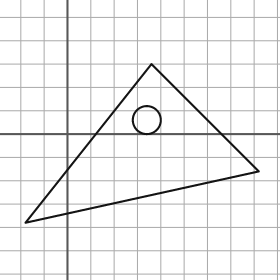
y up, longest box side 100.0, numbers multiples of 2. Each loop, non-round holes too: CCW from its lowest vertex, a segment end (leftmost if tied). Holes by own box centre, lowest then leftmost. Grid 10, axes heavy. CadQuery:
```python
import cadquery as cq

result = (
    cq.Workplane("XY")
    .moveTo(-18.0, -38.0)
    .lineTo(82.0, -16.0)
    .lineTo(36.0, 30.0)
    .close()
    .moveTo(34.0, 6.0)
    .circle(6.0)
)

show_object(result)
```